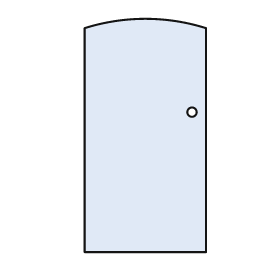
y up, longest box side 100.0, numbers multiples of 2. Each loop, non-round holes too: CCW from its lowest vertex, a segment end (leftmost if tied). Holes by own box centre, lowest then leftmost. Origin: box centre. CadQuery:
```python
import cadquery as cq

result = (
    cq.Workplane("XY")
    .moveTo(-26.0, -50.0)
    .lineTo(26.0, -50.0)
    .lineTo(26.0, 46.0)
    .threePointArc((0.0, 50.0), (-26.0, 46.0))
    .close()
    .moveTo(20.0, 10.0)
    .circle(2.0)
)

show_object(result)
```